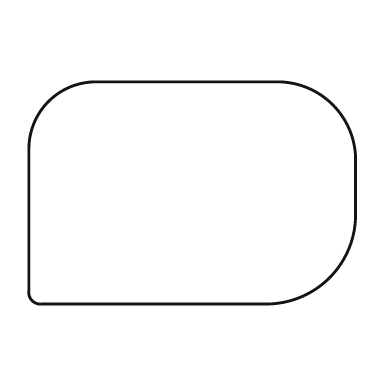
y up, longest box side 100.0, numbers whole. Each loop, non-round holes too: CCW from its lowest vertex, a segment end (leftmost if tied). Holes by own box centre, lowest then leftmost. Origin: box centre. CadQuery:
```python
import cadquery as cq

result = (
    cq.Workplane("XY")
    .moveTo(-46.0, -34.0)
    .lineTo(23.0, -34.0)
    .threePointArc((42.0, -26.0), (50.0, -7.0))
    .lineTo(50.0, 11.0)
    .threePointArc((43.0, 27.0), (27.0, 34.0))
    .lineTo(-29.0, 34.0)
    .threePointArc((-44.0, 28.0), (-50.0, 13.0))
    .lineTo(-50.0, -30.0)
    .threePointArc((-49.0, -33.0), (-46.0, -34.0))
    .close()
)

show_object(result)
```